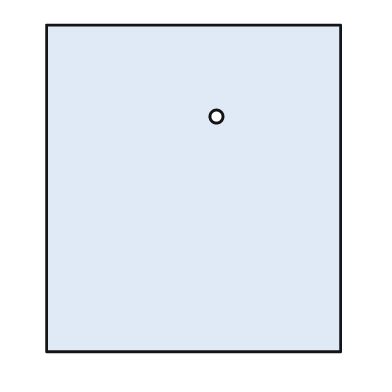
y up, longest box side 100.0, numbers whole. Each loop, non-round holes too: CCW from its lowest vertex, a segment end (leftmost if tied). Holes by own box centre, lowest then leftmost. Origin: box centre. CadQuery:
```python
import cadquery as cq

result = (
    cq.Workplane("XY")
    .moveTo(-45.0, -50.0)
    .lineTo(45.0, -50.0)
    .lineTo(45.0, 50.0)
    .lineTo(-45.0, 50.0)
    .close()
    .moveTo(7.0, 22.0)
    .circle(2.0)
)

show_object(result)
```